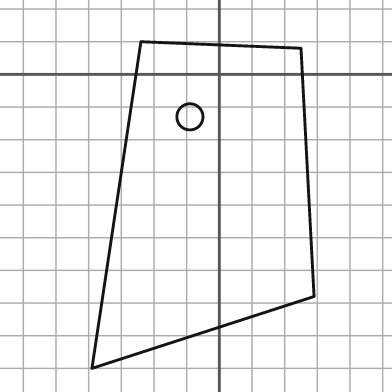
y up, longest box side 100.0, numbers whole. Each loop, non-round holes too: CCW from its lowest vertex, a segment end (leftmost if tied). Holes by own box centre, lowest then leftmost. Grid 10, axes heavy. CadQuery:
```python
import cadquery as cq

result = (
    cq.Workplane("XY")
    .moveTo(-39.0, -90.0)
    .lineTo(29.0, -68.0)
    .lineTo(25.0, 8.0)
    .lineTo(-24.0, 10.0)
    .close()
    .moveTo(-9.0, -13.0)
    .circle(4.0)
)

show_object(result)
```